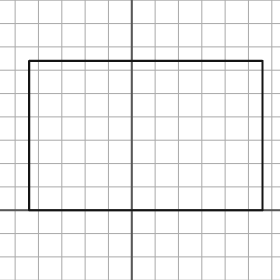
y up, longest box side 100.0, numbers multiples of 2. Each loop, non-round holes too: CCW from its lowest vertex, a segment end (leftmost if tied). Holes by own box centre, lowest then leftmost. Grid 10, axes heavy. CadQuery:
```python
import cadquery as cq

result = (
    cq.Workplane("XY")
    .moveTo(-44.0, 0.0)
    .lineTo(56.0, 0.0)
    .lineTo(56.0, 64.0)
    .lineTo(-44.0, 64.0)
    .close()
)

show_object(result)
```